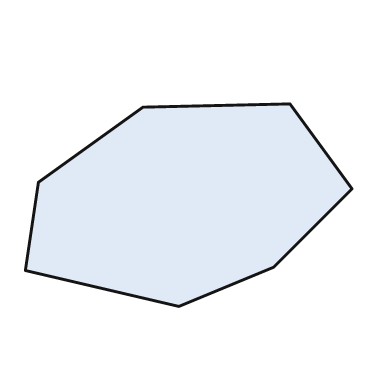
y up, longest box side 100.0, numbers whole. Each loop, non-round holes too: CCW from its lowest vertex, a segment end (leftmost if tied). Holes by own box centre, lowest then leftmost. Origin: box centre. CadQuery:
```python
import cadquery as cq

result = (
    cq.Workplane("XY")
    .moveTo(-3.0, -31.0)
    .lineTo(26.0, -19.0)
    .lineTo(50.0, 5.0)
    .lineTo(31.0, 31.0)
    .lineTo(-14.0, 30.0)
    .lineTo(-46.0, 7.0)
    .lineTo(-50.0, -20.0)
    .close()
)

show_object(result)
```